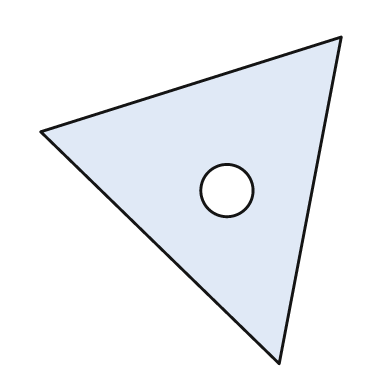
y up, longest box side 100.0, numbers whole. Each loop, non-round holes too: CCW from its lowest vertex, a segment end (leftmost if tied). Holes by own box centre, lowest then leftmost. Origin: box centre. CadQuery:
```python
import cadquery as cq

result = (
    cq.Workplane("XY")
    .moveTo(27.0, -50.0)
    .lineTo(46.0, 50.0)
    .lineTo(-46.0, 21.0)
    .close()
    .moveTo(11.0, 3.0)
    .circle(8.0)
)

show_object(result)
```